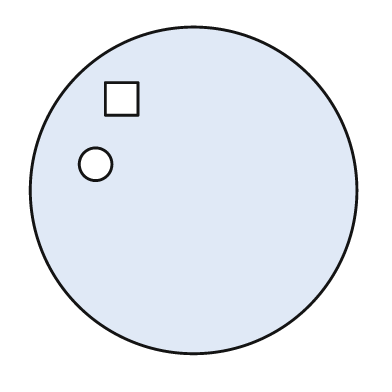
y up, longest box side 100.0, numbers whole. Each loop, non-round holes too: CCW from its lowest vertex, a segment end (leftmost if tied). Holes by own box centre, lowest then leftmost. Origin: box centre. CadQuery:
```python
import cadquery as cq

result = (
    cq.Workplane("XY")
    .moveTo(0.0, 0.0)
    .circle(50.0)
    .moveTo(-30.0, 8.0)
    .circle(5.0)
    .moveTo(-27.0, 23.0)
    .lineTo(-17.0, 23.0)
    .lineTo(-17.0, 33.0)
    .lineTo(-27.0, 33.0)
    .close()
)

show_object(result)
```